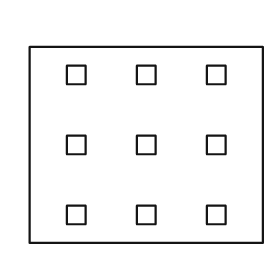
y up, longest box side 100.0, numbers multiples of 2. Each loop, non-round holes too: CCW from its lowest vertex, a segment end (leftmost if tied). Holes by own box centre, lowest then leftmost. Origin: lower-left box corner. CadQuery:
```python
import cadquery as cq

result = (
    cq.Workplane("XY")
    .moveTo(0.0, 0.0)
    .lineTo(100.0, 0.0)
    .lineTo(100.0, 84.0)
    .lineTo(0.0, 84.0)
    .close()
    .moveTo(16.0, 8.0)
    .lineTo(24.0, 8.0)
    .lineTo(24.0, 16.0)
    .lineTo(16.0, 16.0)
    .close()
    .moveTo(46.0, 8.0)
    .lineTo(54.0, 8.0)
    .lineTo(54.0, 16.0)
    .lineTo(46.0, 16.0)
    .close()
    .moveTo(76.0, 8.0)
    .lineTo(84.0, 8.0)
    .lineTo(84.0, 16.0)
    .lineTo(76.0, 16.0)
    .close()
    .moveTo(16.0, 38.0)
    .lineTo(24.0, 38.0)
    .lineTo(24.0, 46.0)
    .lineTo(16.0, 46.0)
    .close()
    .moveTo(46.0, 38.0)
    .lineTo(54.0, 38.0)
    .lineTo(54.0, 46.0)
    .lineTo(46.0, 46.0)
    .close()
    .moveTo(76.0, 38.0)
    .lineTo(84.0, 38.0)
    .lineTo(84.0, 46.0)
    .lineTo(76.0, 46.0)
    .close()
    .moveTo(16.0, 68.0)
    .lineTo(24.0, 68.0)
    .lineTo(24.0, 76.0)
    .lineTo(16.0, 76.0)
    .close()
    .moveTo(46.0, 68.0)
    .lineTo(54.0, 68.0)
    .lineTo(54.0, 76.0)
    .lineTo(46.0, 76.0)
    .close()
    .moveTo(76.0, 68.0)
    .lineTo(84.0, 68.0)
    .lineTo(84.0, 76.0)
    .lineTo(76.0, 76.0)
    .close()
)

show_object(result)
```